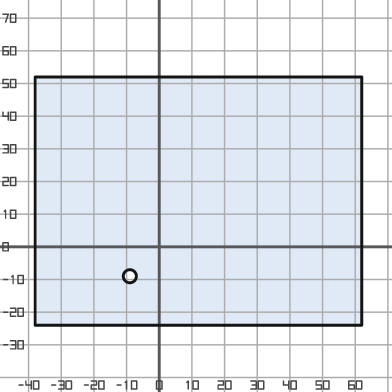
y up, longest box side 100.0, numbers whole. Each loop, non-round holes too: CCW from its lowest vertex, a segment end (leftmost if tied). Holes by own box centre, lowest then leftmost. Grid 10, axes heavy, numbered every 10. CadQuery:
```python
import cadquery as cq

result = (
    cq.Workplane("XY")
    .moveTo(-38.0, -24.0)
    .lineTo(62.0, -24.0)
    .lineTo(62.0, 52.0)
    .lineTo(-38.0, 52.0)
    .close()
    .moveTo(-9.0, -9.0)
    .circle(2.0)
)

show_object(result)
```